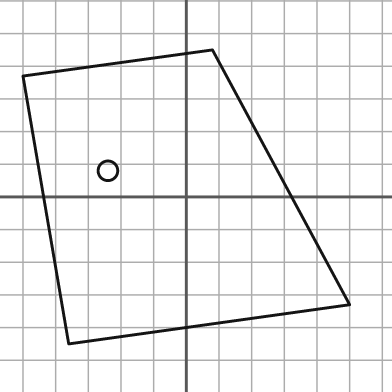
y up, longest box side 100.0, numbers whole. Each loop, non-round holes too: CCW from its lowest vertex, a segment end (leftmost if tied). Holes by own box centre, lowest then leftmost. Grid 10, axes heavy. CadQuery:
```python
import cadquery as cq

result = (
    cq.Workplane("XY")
    .moveTo(-36.0, -45.0)
    .lineTo(50.0, -33.0)
    .lineTo(8.0, 45.0)
    .lineTo(-50.0, 37.0)
    .close()
    .moveTo(-24.0, 8.0)
    .circle(3.0)
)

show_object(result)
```